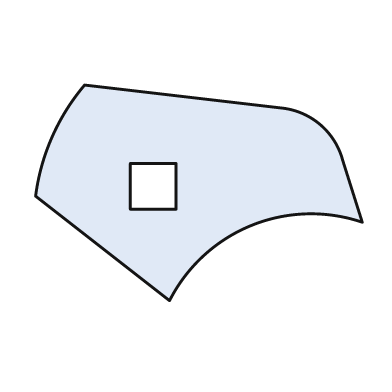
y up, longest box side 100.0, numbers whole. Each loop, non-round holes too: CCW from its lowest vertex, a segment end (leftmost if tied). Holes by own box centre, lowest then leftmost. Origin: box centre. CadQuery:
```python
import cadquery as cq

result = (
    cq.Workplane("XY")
    .moveTo(-9.0, -33.0)
    .threePointArc((16.0, -10.0), (50.0, -9.0))
    .lineTo(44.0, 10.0)
    .threePointArc((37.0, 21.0), (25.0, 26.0))
    .lineTo(-35.0, 33.0)
    .threePointArc((-45.0, 17.0), (-50.0, -1.0))
    .close()
    .moveTo(-21.0, -5.0)
    .lineTo(-7.0, -5.0)
    .lineTo(-7.0, 9.0)
    .lineTo(-21.0, 9.0)
    .close()
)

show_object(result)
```